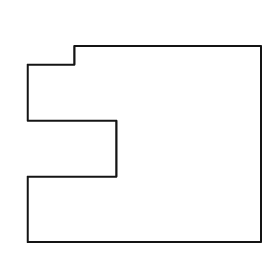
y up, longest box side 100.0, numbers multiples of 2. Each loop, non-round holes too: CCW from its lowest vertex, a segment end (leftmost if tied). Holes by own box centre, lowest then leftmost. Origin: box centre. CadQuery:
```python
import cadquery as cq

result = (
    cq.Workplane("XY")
    .moveTo(-50.0, -42.0)
    .lineTo(50.0, -42.0)
    .lineTo(50.0, 42.0)
    .lineTo(-30.0, 42.0)
    .lineTo(-30.0, 34.0)
    .lineTo(-50.0, 34.0)
    .lineTo(-50.0, 10.0)
    .lineTo(-12.0, 10.0)
    .lineTo(-12.0, -14.0)
    .lineTo(-50.0, -14.0)
    .close()
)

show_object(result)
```